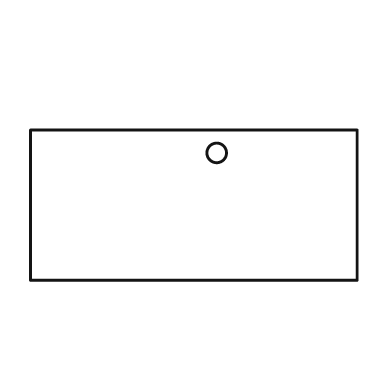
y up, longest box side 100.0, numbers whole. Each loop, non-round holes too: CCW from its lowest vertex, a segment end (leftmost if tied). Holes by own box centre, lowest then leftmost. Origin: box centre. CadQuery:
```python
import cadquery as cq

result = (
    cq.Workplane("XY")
    .moveTo(-50.0, -23.0)
    .lineTo(50.0, -23.0)
    .lineTo(50.0, 23.0)
    .lineTo(-50.0, 23.0)
    .close()
    .moveTo(7.0, 16.0)
    .circle(3.0)
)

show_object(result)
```